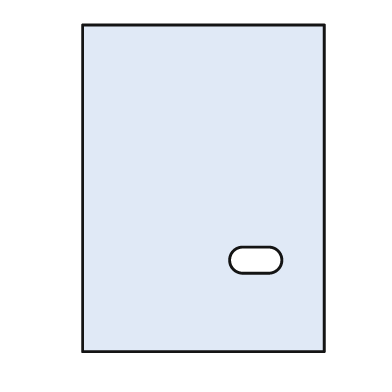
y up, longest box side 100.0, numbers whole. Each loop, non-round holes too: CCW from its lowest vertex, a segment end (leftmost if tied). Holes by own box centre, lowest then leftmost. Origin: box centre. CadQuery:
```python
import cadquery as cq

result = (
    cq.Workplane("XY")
    .moveTo(-37.0, -50.0)
    .lineTo(37.0, -50.0)
    .lineTo(37.0, 50.0)
    .lineTo(-37.0, 50.0)
    .close()
    .moveTo(12.0, -26.0)
    .lineTo(20.0, -26.0)
    .threePointArc((24.0, -22.0), (20.0, -18.0))
    .lineTo(12.0, -18.0)
    .threePointArc((8.0, -22.0), (12.0, -26.0))
    .close()
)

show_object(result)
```